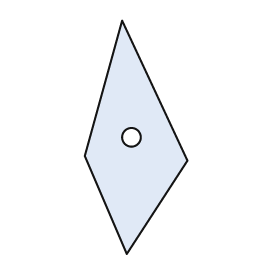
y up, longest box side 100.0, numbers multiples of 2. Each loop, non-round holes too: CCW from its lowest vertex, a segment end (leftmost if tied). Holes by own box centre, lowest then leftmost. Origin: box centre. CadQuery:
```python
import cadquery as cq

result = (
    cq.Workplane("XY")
    .moveTo(-4.0, -50.0)
    .lineTo(22.0, -10.0)
    .lineTo(-6.0, 50.0)
    .lineTo(-22.0, -8.0)
    .close()
    .moveTo(-2.0, 0.0)
    .circle(4.0)
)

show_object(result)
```